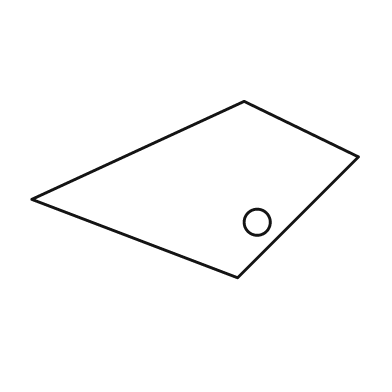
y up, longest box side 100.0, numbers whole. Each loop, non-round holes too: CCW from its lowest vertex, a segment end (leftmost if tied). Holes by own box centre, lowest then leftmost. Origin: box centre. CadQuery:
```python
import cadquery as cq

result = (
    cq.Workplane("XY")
    .moveTo(13.0, -27.0)
    .lineTo(50.0, 10.0)
    .lineTo(15.0, 27.0)
    .lineTo(-50.0, -3.0)
    .close()
    .moveTo(19.0, -10.0)
    .circle(4.0)
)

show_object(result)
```